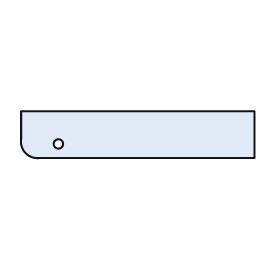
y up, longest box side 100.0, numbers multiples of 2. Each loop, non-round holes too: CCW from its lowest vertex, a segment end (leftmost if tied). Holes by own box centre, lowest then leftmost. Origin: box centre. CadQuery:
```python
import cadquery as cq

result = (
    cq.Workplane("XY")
    .moveTo(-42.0, -10.0)
    .lineTo(50.0, -10.0)
    .lineTo(50.0, 10.0)
    .lineTo(-50.0, 10.0)
    .lineTo(-50.0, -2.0)
    .threePointArc((-48.0, -8.0), (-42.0, -10.0))
    .close()
    .moveTo(-34.0, -4.0)
    .circle(2.0)
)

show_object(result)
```